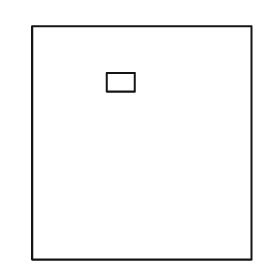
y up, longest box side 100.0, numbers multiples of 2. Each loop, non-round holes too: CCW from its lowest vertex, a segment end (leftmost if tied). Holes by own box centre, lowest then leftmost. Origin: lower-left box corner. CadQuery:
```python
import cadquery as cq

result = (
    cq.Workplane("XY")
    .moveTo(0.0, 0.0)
    .lineTo(94.0, 0.0)
    .lineTo(94.0, 100.0)
    .lineTo(0.0, 100.0)
    .close()
    .moveTo(32.0, 72.0)
    .lineTo(44.0, 72.0)
    .lineTo(44.0, 80.0)
    .lineTo(32.0, 80.0)
    .close()
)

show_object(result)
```